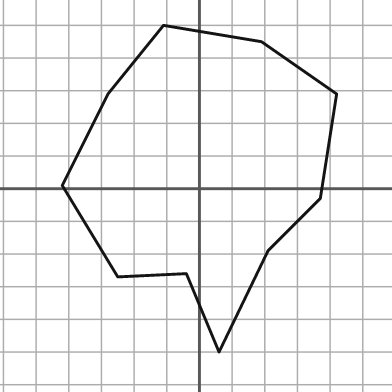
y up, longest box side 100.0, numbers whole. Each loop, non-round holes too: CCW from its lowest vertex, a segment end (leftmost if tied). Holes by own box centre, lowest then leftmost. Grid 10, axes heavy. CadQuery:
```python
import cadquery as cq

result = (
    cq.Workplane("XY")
    .moveTo(6.0, -50.0)
    .lineTo(21.0, -19.0)
    .lineTo(37.0, -3.0)
    .lineTo(42.0, 29.0)
    .lineTo(19.0, 45.0)
    .lineTo(-11.0, 50.0)
    .lineTo(-28.0, 29.0)
    .lineTo(-42.0, 1.0)
    .lineTo(-25.0, -27.0)
    .lineTo(-4.0, -26.0)
    .close()
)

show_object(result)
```